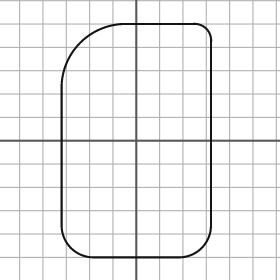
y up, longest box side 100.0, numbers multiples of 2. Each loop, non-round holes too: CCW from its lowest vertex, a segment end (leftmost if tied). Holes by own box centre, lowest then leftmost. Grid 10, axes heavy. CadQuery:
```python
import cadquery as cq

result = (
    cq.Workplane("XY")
    .moveTo(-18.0, -50.0)
    .lineTo(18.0, -50.0)
    .threePointArc((28.0, -46.0), (32.0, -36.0))
    .lineTo(32.0, 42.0)
    .threePointArc((30.0, 48.0), (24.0, 50.0))
    .lineTo(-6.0, 50.0)
    .threePointArc((-24.0, 42.0), (-32.0, 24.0))
    .lineTo(-32.0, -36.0)
    .threePointArc((-28.0, -46.0), (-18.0, -50.0))
    .close()
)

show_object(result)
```